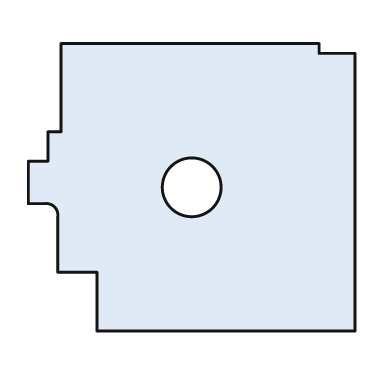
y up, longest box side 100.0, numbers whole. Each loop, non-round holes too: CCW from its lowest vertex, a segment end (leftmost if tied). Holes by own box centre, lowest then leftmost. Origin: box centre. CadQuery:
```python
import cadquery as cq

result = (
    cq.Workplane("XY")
    .moveTo(-29.0, -44.0)
    .lineTo(50.0, -44.0)
    .lineTo(50.0, 41.0)
    .lineTo(39.0, 41.0)
    .lineTo(39.0, 44.0)
    .lineTo(-40.0, 44.0)
    .lineTo(-40.0, 17.0)
    .lineTo(-44.0, 17.0)
    .lineTo(-44.0, 8.0)
    .lineTo(-50.0, 8.0)
    .lineTo(-50.0, -5.0)
    .lineTo(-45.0, -5.0)
    .threePointArc((-42.0, -6.0), (-41.0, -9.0))
    .lineTo(-41.0, -26.0)
    .lineTo(-29.0, -26.0)
    .close()
    .moveTo(0.0, 0.0)
    .circle(9.0)
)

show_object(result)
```